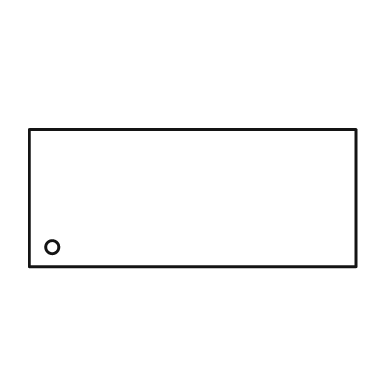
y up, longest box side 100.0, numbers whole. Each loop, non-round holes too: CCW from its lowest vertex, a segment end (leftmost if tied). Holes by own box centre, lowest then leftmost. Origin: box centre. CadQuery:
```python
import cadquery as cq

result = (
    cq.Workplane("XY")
    .moveTo(-50.0, -21.0)
    .lineTo(50.0, -21.0)
    .lineTo(50.0, 21.0)
    .lineTo(-50.0, 21.0)
    .close()
    .moveTo(-43.0, -15.0)
    .circle(2.0)
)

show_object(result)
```